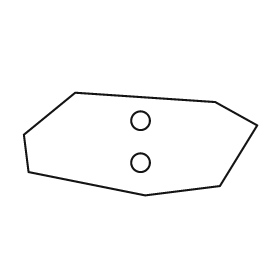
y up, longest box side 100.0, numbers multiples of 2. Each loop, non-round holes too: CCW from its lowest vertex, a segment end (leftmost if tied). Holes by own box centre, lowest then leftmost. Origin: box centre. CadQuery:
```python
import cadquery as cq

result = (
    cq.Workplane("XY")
    .moveTo(2.0, -22.0)
    .lineTo(34.0, -18.0)
    .lineTo(50.0, 8.0)
    .lineTo(32.0, 18.0)
    .lineTo(-28.0, 22.0)
    .lineTo(-50.0, 4.0)
    .lineTo(-48.0, -12.0)
    .close()
    .moveTo(0.0, -8.0)
    .circle(4.0)
    .moveTo(0.0, 10.0)
    .circle(4.0)
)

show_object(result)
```